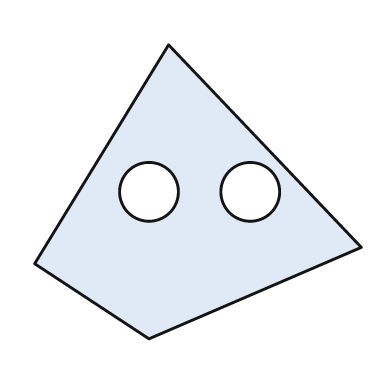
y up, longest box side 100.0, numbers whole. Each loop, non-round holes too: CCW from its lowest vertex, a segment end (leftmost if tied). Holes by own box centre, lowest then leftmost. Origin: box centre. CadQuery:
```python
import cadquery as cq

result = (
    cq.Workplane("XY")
    .moveTo(-15.0, -45.0)
    .lineTo(50.0, -17.0)
    .lineTo(-9.0, 45.0)
    .lineTo(-50.0, -22.0)
    .close()
    .moveTo(-15.0, 0.0)
    .circle(9.0)
    .moveTo(16.0, 0.0)
    .circle(9.0)
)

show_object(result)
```